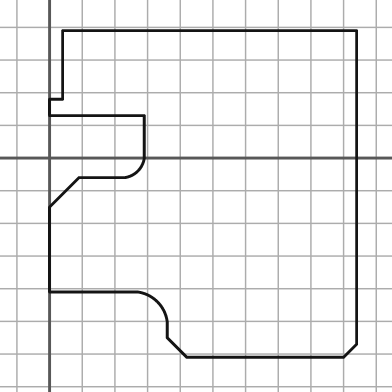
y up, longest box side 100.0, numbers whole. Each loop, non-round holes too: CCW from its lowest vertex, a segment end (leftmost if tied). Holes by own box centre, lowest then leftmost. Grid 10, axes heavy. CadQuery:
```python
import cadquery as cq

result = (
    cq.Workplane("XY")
    .moveTo(42.0, -61.0)
    .lineTo(90.0, -61.0)
    .lineTo(94.0, -57.0)
    .lineTo(94.0, 39.0)
    .lineTo(4.0, 39.0)
    .lineTo(4.0, 18.0)
    .lineTo(0.0, 18.0)
    .lineTo(0.0, 13.0)
    .lineTo(29.0, 13.0)
    .lineTo(29.0, 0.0)
    .threePointArc((27.0, -4.0), (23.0, -6.0))
    .lineTo(9.0, -6.0)
    .lineTo(0.0, -15.0)
    .lineTo(0.0, -41.0)
    .lineTo(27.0, -41.0)
    .threePointArc((33.0, -44.0), (36.0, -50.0))
    .lineTo(36.0, -55.0)
    .close()
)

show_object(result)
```